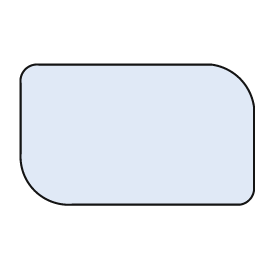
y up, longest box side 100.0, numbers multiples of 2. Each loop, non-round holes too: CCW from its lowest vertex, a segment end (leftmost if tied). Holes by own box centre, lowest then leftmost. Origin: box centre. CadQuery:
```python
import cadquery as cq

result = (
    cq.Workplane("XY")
    .moveTo(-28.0, -30.0)
    .lineTo(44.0, -30.0)
    .threePointArc((48.0, -28.0), (50.0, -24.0))
    .lineTo(50.0, 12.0)
    .threePointArc((44.0, 24.0), (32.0, 30.0))
    .lineTo(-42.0, 30.0)
    .threePointArc((-48.0, 28.0), (-50.0, 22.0))
    .lineTo(-50.0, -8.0)
    .threePointArc((-44.0, -24.0), (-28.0, -30.0))
    .close()
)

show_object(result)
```